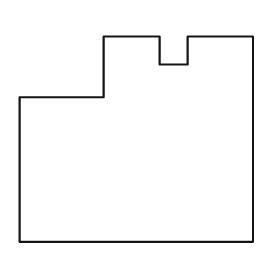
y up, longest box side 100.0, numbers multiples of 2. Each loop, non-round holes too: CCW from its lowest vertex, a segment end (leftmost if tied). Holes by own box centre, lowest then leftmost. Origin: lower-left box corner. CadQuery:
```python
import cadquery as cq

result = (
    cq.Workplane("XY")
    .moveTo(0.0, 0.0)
    .lineTo(100.0, 0.0)
    .lineTo(100.0, 88.0)
    .lineTo(72.0, 88.0)
    .lineTo(72.0, 76.0)
    .lineTo(60.0, 76.0)
    .lineTo(60.0, 88.0)
    .lineTo(36.0, 88.0)
    .lineTo(36.0, 62.0)
    .lineTo(0.0, 62.0)
    .close()
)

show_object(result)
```